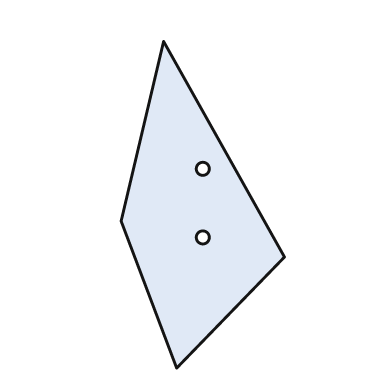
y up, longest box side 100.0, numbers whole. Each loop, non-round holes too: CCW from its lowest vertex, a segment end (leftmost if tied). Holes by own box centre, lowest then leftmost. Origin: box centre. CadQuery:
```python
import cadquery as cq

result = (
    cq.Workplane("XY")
    .moveTo(-8.0, -50.0)
    .lineTo(25.0, -16.0)
    .lineTo(-12.0, 50.0)
    .lineTo(-25.0, -5.0)
    .close()
    .moveTo(0.0, -10.0)
    .circle(2.0)
    .moveTo(0.0, 11.0)
    .circle(2.0)
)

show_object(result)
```